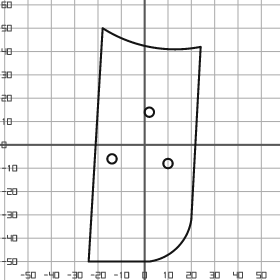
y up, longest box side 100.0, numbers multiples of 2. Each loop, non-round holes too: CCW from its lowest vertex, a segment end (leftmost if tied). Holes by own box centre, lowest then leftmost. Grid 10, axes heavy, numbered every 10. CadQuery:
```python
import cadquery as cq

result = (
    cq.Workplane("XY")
    .moveTo(-24.0, -50.0)
    .lineTo(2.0, -50.0)
    .threePointArc((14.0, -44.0), (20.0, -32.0))
    .lineTo(24.0, 42.0)
    .threePointArc((2.0, 42.0), (-18.0, 50.0))
    .close()
    .moveTo(10.0, -8.0)
    .circle(2.0)
    .moveTo(-14.0, -6.0)
    .circle(2.0)
    .moveTo(2.0, 14.0)
    .circle(2.0)
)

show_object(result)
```